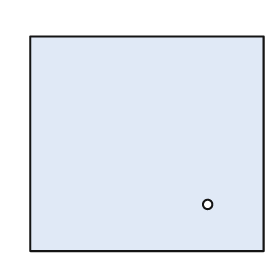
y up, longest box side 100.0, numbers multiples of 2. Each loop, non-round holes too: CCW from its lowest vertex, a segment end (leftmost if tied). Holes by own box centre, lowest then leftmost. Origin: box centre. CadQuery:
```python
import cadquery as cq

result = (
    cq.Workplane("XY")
    .moveTo(-50.0, -46.0)
    .lineTo(50.0, -46.0)
    .lineTo(50.0, 46.0)
    .lineTo(-50.0, 46.0)
    .close()
    .moveTo(26.0, -26.0)
    .circle(2.0)
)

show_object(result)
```